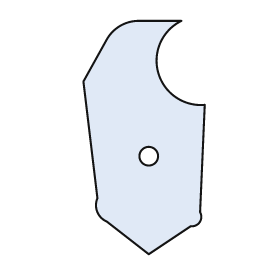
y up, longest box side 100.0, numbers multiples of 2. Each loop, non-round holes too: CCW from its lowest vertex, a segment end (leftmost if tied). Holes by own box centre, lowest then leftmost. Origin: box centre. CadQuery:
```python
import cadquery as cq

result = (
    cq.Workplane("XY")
    .moveTo(2.0, -50.0)
    .lineTo(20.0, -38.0)
    .threePointArc((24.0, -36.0), (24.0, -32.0))
    .lineTo(26.0, 14.0)
    .threePointArc((6.0, 28.0), (16.0, 50.0))
    .lineTo(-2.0, 50.0)
    .threePointArc((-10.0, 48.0), (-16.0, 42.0))
    .lineTo(-26.0, 24.0)
    .lineTo(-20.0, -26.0)
    .threePointArc((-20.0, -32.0), (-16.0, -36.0))
    .close()
    .moveTo(2.0, -8.0)
    .circle(4.0)
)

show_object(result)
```